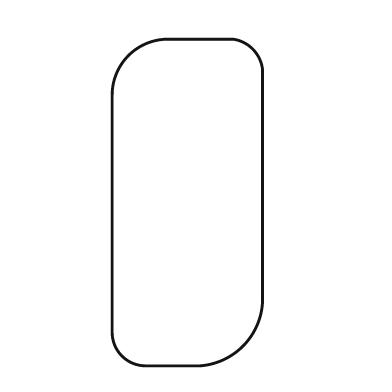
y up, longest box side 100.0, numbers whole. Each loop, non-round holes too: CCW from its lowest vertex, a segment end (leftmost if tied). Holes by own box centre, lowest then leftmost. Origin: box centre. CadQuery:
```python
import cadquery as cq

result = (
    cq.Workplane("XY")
    .moveTo(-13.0, -50.0)
    .lineTo(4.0, -50.0)
    .threePointArc((17.0, -44.0), (23.0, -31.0))
    .lineTo(23.0, 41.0)
    .threePointArc((20.0, 47.0), (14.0, 50.0))
    .lineTo(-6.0, 50.0)
    .threePointArc((-18.0, 45.0), (-23.0, 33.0))
    .lineTo(-23.0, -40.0)
    .threePointArc((-20.0, -47.0), (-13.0, -50.0))
    .close()
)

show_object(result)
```